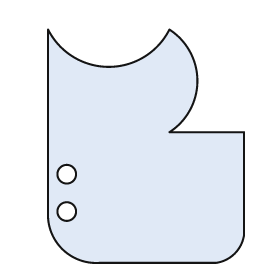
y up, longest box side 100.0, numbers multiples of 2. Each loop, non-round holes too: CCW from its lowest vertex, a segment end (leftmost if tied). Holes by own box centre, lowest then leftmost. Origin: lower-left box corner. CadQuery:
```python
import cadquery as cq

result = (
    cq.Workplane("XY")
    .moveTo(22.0, 0.0)
    .lineTo(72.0, 0.0)
    .threePointArc((80.0, 4.0), (84.0, 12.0))
    .lineTo(84.0, 56.0)
    .lineTo(52.0, 56.0)
    .threePointArc((64.0, 78.0), (52.0, 100.0))
    .threePointArc((26.0, 84.0), (0.0, 100.0))
    .lineTo(0.0, 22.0)
    .threePointArc((6.0, 6.0), (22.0, 0.0))
    .close()
    .moveTo(8.0, 22.0)
    .circle(4.0)
    .moveTo(8.0, 38.0)
    .circle(4.0)
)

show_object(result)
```